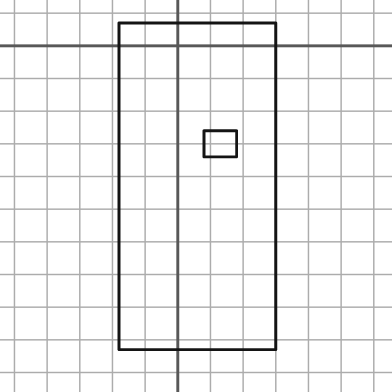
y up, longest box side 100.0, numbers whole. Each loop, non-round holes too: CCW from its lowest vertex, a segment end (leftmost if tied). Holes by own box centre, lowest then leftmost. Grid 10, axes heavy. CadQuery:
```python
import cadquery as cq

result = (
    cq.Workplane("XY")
    .moveTo(-18.0, -93.0)
    .lineTo(30.0, -93.0)
    .lineTo(30.0, 7.0)
    .lineTo(-18.0, 7.0)
    .close()
    .moveTo(8.0, -34.0)
    .lineTo(18.0, -34.0)
    .lineTo(18.0, -26.0)
    .lineTo(8.0, -26.0)
    .close()
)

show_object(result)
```